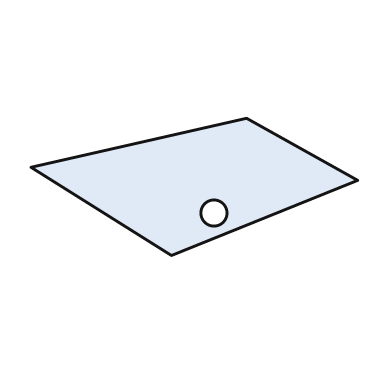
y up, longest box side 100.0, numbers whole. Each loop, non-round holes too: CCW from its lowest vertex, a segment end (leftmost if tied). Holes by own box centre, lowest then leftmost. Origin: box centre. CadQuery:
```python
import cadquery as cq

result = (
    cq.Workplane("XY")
    .moveTo(-7.0, -21.0)
    .lineTo(50.0, 2.0)
    .lineTo(16.0, 21.0)
    .lineTo(-50.0, 6.0)
    .close()
    .moveTo(6.0, -8.0)
    .circle(4.0)
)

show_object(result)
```